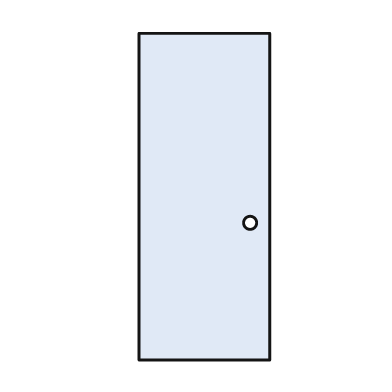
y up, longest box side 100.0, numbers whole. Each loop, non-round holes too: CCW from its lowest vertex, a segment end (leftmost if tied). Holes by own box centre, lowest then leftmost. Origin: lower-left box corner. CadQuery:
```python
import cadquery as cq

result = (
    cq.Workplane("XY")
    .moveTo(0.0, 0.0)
    .lineTo(40.0, 0.0)
    .lineTo(40.0, 100.0)
    .lineTo(0.0, 100.0)
    .close()
    .moveTo(34.0, 42.0)
    .circle(2.0)
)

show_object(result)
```